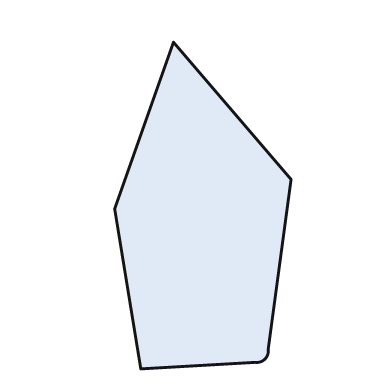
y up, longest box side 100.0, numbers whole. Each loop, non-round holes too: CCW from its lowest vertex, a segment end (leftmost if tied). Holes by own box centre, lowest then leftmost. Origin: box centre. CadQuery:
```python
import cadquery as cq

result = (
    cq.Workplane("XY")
    .moveTo(-19.0, -50.0)
    .lineTo(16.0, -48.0)
    .threePointArc((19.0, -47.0), (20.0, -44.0))
    .lineTo(27.0, 8.0)
    .lineTo(-9.0, 50.0)
    .lineTo(-27.0, -1.0)
    .close()
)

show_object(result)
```